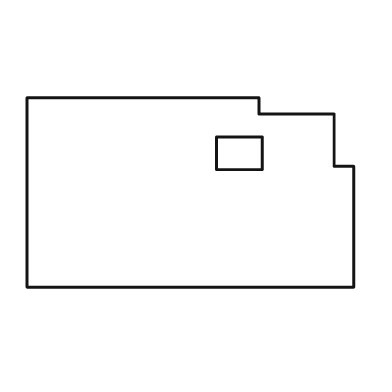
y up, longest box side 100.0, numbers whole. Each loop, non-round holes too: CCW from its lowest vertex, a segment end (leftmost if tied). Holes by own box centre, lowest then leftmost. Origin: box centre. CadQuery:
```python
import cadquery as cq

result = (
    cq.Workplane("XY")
    .moveTo(-50.0, -29.0)
    .lineTo(50.0, -29.0)
    .lineTo(50.0, 8.0)
    .lineTo(44.0, 8.0)
    .lineTo(44.0, 24.0)
    .lineTo(21.0, 24.0)
    .lineTo(21.0, 29.0)
    .lineTo(-50.0, 29.0)
    .close()
    .moveTo(8.0, 7.0)
    .lineTo(22.0, 7.0)
    .lineTo(22.0, 17.0)
    .lineTo(8.0, 17.0)
    .close()
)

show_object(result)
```